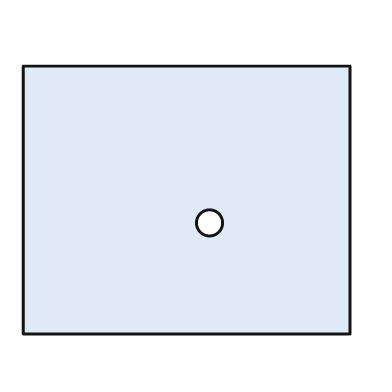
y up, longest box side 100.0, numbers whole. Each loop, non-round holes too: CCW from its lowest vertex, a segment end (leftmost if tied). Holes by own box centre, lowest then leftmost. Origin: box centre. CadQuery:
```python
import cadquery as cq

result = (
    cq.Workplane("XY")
    .moveTo(-50.0, -41.0)
    .lineTo(50.0, -41.0)
    .lineTo(50.0, 41.0)
    .lineTo(-50.0, 41.0)
    .close()
    .moveTo(7.0, -7.0)
    .circle(4.0)
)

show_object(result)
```